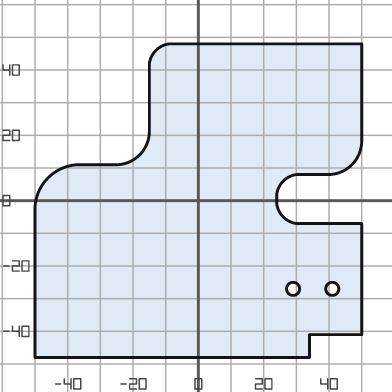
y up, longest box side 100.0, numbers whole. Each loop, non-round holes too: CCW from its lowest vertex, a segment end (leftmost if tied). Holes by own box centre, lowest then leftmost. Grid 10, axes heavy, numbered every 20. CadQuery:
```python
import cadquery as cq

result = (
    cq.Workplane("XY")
    .moveTo(-50.0, -48.0)
    .lineTo(34.0, -48.0)
    .lineTo(34.0, -41.0)
    .lineTo(50.0, -41.0)
    .lineTo(50.0, -7.0)
    .lineTo(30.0, -7.0)
    .threePointArc((26.0, -5.0), (24.0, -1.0))
    .lineTo(24.0, 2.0)
    .threePointArc((26.0, 6.0), (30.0, 8.0))
    .lineTo(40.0, 8.0)
    .threePointArc((47.0, 11.0), (50.0, 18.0))
    .lineTo(50.0, 48.0)
    .lineTo(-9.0, 48.0)
    .threePointArc((-13.0, 46.0), (-15.0, 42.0))
    .lineTo(-15.0, 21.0)
    .threePointArc((-18.0, 14.0), (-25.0, 11.0))
    .lineTo(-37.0, 11.0)
    .threePointArc((-46.0, 7.0), (-50.0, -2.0))
    .close()
    .moveTo(29.0, -27.0)
    .circle(2.0)
    .moveTo(41.0, -27.0)
    .circle(2.0)
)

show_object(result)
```